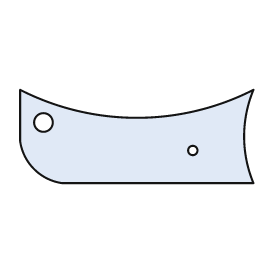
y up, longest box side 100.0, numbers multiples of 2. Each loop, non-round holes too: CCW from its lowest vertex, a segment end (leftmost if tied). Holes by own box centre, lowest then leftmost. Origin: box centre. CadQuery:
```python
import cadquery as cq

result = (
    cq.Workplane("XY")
    .moveTo(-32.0, -20.0)
    .lineTo(50.0, -20.0)
    .threePointArc((46.0, 0.0), (50.0, 20.0))
    .threePointArc((0.0, 8.0), (-50.0, 20.0))
    .lineTo(-50.0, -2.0)
    .threePointArc((-44.0, -14.0), (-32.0, -20.0))
    .close()
    .moveTo(24.0, -6.0)
    .circle(2.0)
    .moveTo(-40.0, 6.0)
    .circle(4.0)
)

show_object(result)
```